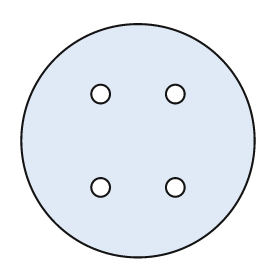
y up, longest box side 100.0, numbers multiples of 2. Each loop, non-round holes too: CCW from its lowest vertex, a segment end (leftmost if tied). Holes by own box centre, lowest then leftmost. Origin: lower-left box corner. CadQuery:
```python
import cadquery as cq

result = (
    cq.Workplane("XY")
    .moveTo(50.0, 50.0)
    .circle(50.0)
    .moveTo(34.0, 30.0)
    .circle(4.0)
    .moveTo(66.0, 30.0)
    .circle(4.0)
    .moveTo(34.0, 70.0)
    .circle(4.0)
    .moveTo(66.0, 70.0)
    .circle(4.0)
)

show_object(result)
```